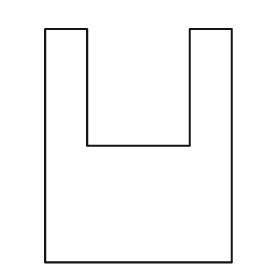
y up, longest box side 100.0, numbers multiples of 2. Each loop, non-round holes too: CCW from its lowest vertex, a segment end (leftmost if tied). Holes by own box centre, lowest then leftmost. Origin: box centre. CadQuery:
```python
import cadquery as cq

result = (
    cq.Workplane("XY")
    .moveTo(-40.0, -50.0)
    .lineTo(40.0, -50.0)
    .lineTo(40.0, 50.0)
    .lineTo(22.0, 50.0)
    .lineTo(22.0, 0.0)
    .lineTo(-22.0, 0.0)
    .lineTo(-22.0, 50.0)
    .lineTo(-40.0, 50.0)
    .close()
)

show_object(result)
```